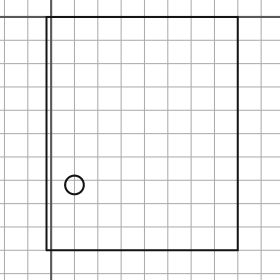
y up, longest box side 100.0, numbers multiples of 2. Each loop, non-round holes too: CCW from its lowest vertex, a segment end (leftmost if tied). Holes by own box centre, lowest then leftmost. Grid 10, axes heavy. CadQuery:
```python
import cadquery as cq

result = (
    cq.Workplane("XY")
    .moveTo(-2.0, -100.0)
    .lineTo(80.0, -100.0)
    .lineTo(80.0, 0.0)
    .lineTo(-2.0, 0.0)
    .close()
    .moveTo(10.0, -72.0)
    .circle(4.0)
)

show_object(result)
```